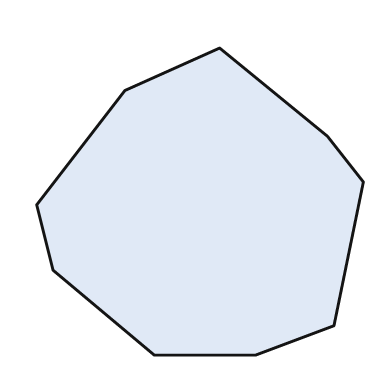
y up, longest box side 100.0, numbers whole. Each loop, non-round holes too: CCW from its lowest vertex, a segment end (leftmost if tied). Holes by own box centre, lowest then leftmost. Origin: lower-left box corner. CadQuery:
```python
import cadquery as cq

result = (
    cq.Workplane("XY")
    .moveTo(36.0, 0.0)
    .lineTo(67.0, 0.0)
    .lineTo(91.0, 9.0)
    .lineTo(100.0, 53.0)
    .lineTo(89.0, 67.0)
    .lineTo(56.0, 94.0)
    .lineTo(27.0, 81.0)
    .lineTo(0.0, 46.0)
    .lineTo(5.0, 26.0)
    .close()
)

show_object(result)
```